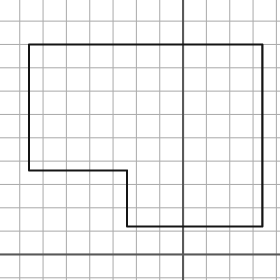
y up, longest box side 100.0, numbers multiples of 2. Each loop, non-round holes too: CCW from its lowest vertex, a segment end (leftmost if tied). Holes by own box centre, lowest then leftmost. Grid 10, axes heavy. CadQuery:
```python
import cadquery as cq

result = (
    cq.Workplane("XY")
    .moveTo(-24.0, 12.0)
    .lineTo(34.0, 12.0)
    .lineTo(34.0, 90.0)
    .lineTo(-66.0, 90.0)
    .lineTo(-66.0, 36.0)
    .lineTo(-24.0, 36.0)
    .close()
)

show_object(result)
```